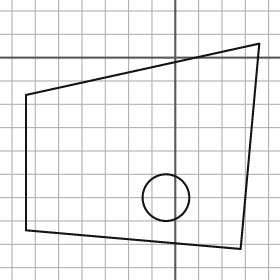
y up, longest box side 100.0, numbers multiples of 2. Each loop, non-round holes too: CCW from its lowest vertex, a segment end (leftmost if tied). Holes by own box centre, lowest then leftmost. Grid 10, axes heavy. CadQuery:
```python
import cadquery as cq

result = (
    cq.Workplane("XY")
    .moveTo(28.0, -82.0)
    .lineTo(36.0, 6.0)
    .lineTo(-64.0, -16.0)
    .lineTo(-64.0, -74.0)
    .close()
    .moveTo(-4.0, -60.0)
    .circle(10.0)
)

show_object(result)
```